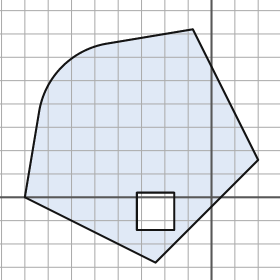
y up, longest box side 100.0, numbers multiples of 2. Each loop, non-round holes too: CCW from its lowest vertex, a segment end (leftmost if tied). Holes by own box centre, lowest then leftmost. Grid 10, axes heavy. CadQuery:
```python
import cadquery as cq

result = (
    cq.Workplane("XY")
    .moveTo(-24.0, -28.0)
    .lineTo(20.0, 16.0)
    .lineTo(-8.0, 72.0)
    .lineTo(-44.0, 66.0)
    .threePointArc((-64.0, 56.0), (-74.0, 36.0))
    .lineTo(-80.0, 0.0)
    .close()
    .moveTo(-32.0, -14.0)
    .lineTo(-16.0, -14.0)
    .lineTo(-16.0, 2.0)
    .lineTo(-32.0, 2.0)
    .close()
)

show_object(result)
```